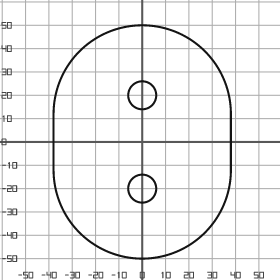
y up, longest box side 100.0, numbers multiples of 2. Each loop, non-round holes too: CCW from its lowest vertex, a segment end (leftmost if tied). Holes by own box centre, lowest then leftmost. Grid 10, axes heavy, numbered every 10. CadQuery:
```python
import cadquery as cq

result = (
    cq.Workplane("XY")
    .moveTo(-38.0, -12.0)
    .threePointArc((0.0, -50.0), (38.0, -12.0))
    .lineTo(38.0, 12.0)
    .threePointArc((0.0, 50.0), (-38.0, 12.0))
    .close()
    .moveTo(0.0, -20.0)
    .circle(6.0)
    .moveTo(0.0, 20.0)
    .circle(6.0)
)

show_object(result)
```